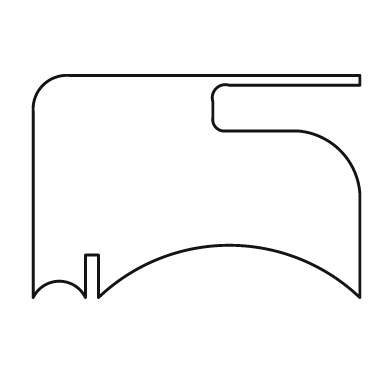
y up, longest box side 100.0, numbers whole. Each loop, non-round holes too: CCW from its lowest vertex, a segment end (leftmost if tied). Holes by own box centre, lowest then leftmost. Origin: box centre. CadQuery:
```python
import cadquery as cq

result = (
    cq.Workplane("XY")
    .moveTo(-50.0, -34.0)
    .threePointArc((-42.0, -29.0), (-34.0, -34.0))
    .lineTo(-34.0, -21.0)
    .lineTo(-30.0, -21.0)
    .lineTo(-30.0, -34.0)
    .threePointArc((10.0, -18.0), (50.0, -34.0))
    .lineTo(50.0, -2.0)
    .threePointArc((44.0, 11.0), (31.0, 17.0))
    .lineTo(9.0, 17.0)
    .threePointArc((6.0, 18.0), (5.0, 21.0))
    .lineTo(5.0, 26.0)
    .threePointArc((6.0, 30.0), (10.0, 31.0))
    .lineTo(50.0, 31.0)
    .lineTo(50.0, 34.0)
    .lineTo(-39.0, 34.0)
    .threePointArc((-47.0, 31.0), (-50.0, 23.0))
    .close()
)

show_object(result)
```